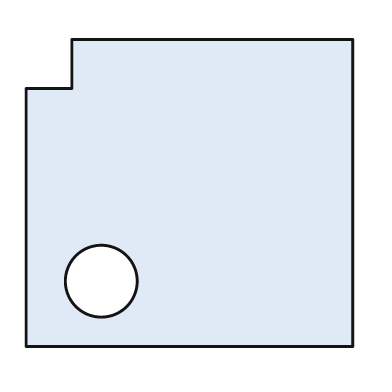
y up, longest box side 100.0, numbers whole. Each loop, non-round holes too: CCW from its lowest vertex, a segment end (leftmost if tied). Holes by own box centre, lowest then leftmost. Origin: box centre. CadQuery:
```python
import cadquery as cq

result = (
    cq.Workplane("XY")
    .moveTo(-50.0, -47.0)
    .lineTo(50.0, -47.0)
    .lineTo(50.0, 47.0)
    .lineTo(-36.0, 47.0)
    .lineTo(-36.0, 32.0)
    .lineTo(-50.0, 32.0)
    .close()
    .moveTo(-27.0, -27.0)
    .circle(11.0)
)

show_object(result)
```